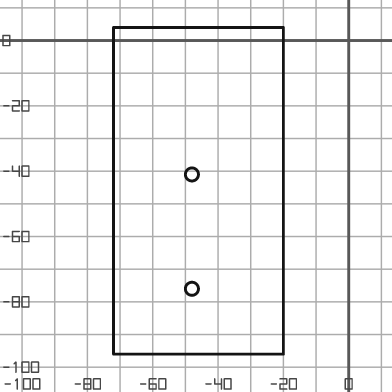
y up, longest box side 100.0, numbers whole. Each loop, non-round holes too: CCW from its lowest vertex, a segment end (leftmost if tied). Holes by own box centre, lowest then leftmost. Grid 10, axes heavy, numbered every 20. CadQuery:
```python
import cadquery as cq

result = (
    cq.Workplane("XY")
    .moveTo(-72.0, -96.0)
    .lineTo(-20.0, -96.0)
    .lineTo(-20.0, 4.0)
    .lineTo(-72.0, 4.0)
    .close()
    .moveTo(-48.0, -76.0)
    .circle(2.0)
    .moveTo(-48.0, -41.0)
    .circle(2.0)
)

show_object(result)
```